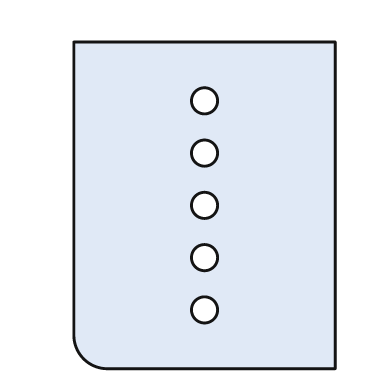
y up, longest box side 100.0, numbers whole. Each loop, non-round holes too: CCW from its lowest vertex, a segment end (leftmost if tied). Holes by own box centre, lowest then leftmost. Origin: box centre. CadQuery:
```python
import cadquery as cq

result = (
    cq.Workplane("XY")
    .moveTo(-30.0, -50.0)
    .lineTo(40.0, -50.0)
    .lineTo(40.0, 50.0)
    .lineTo(-40.0, 50.0)
    .lineTo(-40.0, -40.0)
    .threePointArc((-37.0, -47.0), (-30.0, -50.0))
    .close()
    .moveTo(0.0, -32.0)
    .circle(4.0)
    .moveTo(0.0, -16.0)
    .circle(4.0)
    .moveTo(0.0, 0.0)
    .circle(4.0)
    .moveTo(0.0, 16.0)
    .circle(4.0)
    .moveTo(0.0, 32.0)
    .circle(4.0)
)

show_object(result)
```